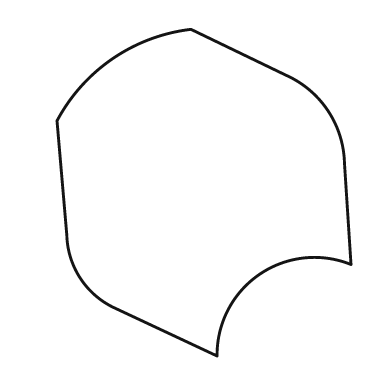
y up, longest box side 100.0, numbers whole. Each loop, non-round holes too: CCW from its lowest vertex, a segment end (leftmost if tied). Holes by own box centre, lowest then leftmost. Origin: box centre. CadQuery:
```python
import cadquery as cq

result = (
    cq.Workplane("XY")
    .moveTo(4.0, -50.0)
    .threePointArc((17.0, -25.0), (45.0, -22.0))
    .lineTo(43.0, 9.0)
    .threePointArc((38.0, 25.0), (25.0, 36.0))
    .lineTo(-4.0, 50.0)
    .threePointArc((-28.0, 41.0), (-45.0, 22.0))
    .lineTo(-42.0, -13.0)
    .threePointArc((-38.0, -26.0), (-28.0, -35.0))
    .close()
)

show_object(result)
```